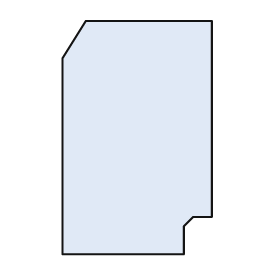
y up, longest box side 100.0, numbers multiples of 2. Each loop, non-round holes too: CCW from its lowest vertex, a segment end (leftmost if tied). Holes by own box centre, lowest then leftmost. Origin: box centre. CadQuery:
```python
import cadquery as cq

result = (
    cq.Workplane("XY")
    .moveTo(-32.0, -50.0)
    .lineTo(20.0, -50.0)
    .lineTo(20.0, -38.0)
    .lineTo(24.0, -34.0)
    .lineTo(32.0, -34.0)
    .lineTo(32.0, 50.0)
    .lineTo(-22.0, 50.0)
    .lineTo(-32.0, 34.0)
    .close()
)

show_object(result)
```